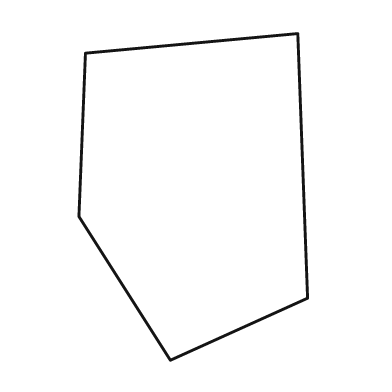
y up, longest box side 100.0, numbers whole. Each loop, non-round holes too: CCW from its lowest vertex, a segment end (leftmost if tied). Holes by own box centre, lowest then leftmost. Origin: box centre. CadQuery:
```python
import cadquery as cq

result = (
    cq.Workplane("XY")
    .moveTo(-7.0, -50.0)
    .lineTo(35.0, -31.0)
    .lineTo(32.0, 50.0)
    .lineTo(-33.0, 44.0)
    .lineTo(-35.0, -6.0)
    .close()
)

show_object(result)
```